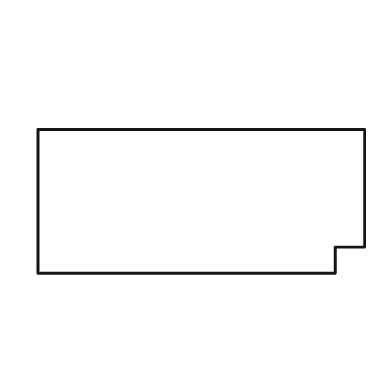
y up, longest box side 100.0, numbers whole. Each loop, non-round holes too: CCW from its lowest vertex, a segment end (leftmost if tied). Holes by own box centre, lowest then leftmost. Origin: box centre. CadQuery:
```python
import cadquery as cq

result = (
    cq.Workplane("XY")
    .moveTo(-50.0, -22.0)
    .lineTo(41.0, -22.0)
    .lineTo(41.0, -14.0)
    .lineTo(50.0, -14.0)
    .lineTo(50.0, 22.0)
    .lineTo(-50.0, 22.0)
    .close()
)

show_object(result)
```